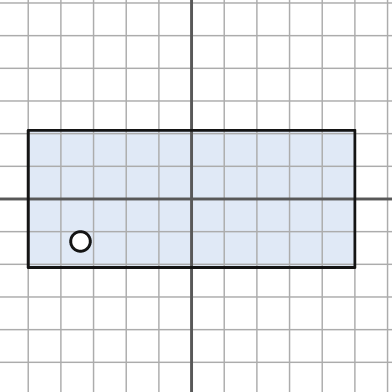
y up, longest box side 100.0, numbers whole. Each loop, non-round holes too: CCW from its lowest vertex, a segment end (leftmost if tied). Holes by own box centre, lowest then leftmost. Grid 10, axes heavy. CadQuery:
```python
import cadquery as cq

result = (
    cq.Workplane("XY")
    .moveTo(-50.0, -21.0)
    .lineTo(50.0, -21.0)
    .lineTo(50.0, 21.0)
    .lineTo(-50.0, 21.0)
    .close()
    .moveTo(-34.0, -13.0)
    .circle(3.0)
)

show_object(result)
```